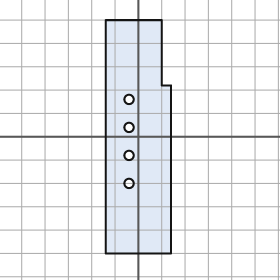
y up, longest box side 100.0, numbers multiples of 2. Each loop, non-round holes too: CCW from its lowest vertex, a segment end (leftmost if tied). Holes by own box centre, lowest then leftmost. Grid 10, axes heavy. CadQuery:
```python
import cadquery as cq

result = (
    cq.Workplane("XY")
    .moveTo(-14.0, -50.0)
    .lineTo(14.0, -50.0)
    .lineTo(14.0, 22.0)
    .lineTo(10.0, 22.0)
    .lineTo(10.0, 50.0)
    .lineTo(-14.0, 50.0)
    .close()
    .moveTo(-4.0, -20.0)
    .circle(2.0)
    .moveTo(-4.0, -8.0)
    .circle(2.0)
    .moveTo(-4.0, 4.0)
    .circle(2.0)
    .moveTo(-4.0, 16.0)
    .circle(2.0)
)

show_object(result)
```